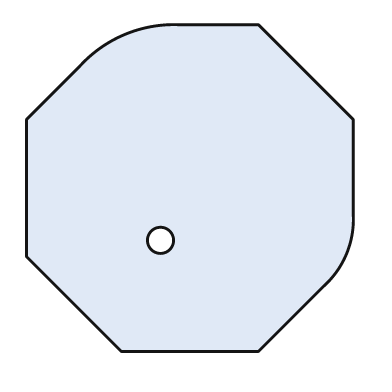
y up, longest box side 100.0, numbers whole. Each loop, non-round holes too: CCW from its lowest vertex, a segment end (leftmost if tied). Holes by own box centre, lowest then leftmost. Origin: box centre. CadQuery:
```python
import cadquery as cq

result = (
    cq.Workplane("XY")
    .moveTo(-21.0, -50.0)
    .lineTo(21.0, -50.0)
    .lineTo(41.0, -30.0)
    .threePointArc((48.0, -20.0), (50.0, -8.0))
    .lineTo(50.0, 21.0)
    .lineTo(21.0, 50.0)
    .lineTo(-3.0, 50.0)
    .threePointArc((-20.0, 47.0), (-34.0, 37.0))
    .lineTo(-50.0, 21.0)
    .lineTo(-50.0, -21.0)
    .close()
    .moveTo(-9.0, -16.0)
    .circle(4.0)
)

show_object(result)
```